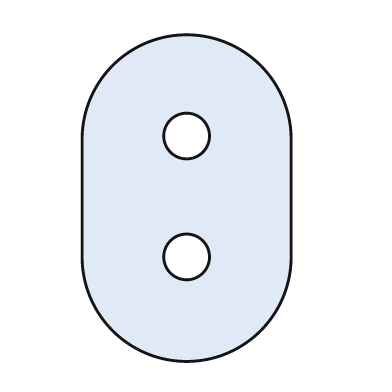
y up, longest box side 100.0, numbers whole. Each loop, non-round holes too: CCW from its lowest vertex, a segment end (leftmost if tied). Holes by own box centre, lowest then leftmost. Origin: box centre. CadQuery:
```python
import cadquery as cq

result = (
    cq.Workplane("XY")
    .moveTo(-32.0, -18.0)
    .threePointArc((0.0, -50.0), (32.0, -18.0))
    .lineTo(32.0, 18.0)
    .threePointArc((0.0, 50.0), (-32.0, 18.0))
    .close()
    .moveTo(0.0, -18.0)
    .circle(7.0)
    .moveTo(0.0, 19.0)
    .circle(7.0)
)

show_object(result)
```